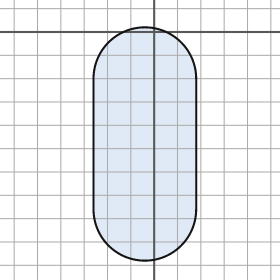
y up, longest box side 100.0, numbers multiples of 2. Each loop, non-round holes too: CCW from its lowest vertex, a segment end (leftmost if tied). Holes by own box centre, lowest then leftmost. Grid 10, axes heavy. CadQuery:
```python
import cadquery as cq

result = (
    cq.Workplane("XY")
    .moveTo(-26.0, -76.0)
    .threePointArc((-4.0, -98.0), (18.0, -76.0))
    .lineTo(18.0, -20.0)
    .threePointArc((-4.0, 2.0), (-26.0, -20.0))
    .close()
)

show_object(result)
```